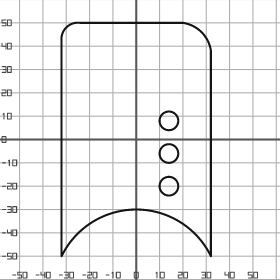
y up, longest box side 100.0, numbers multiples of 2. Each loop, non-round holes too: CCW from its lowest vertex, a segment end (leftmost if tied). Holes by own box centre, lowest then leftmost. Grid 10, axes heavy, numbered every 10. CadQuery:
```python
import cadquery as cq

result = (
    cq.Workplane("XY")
    .moveTo(-32.0, -50.0)
    .threePointArc((0.0, -30.0), (32.0, -50.0))
    .lineTo(32.0, 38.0)
    .threePointArc((28.0, 46.0), (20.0, 50.0))
    .lineTo(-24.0, 50.0)
    .threePointArc((-30.0, 48.0), (-32.0, 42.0))
    .close()
    .moveTo(14.0, -20.0)
    .circle(4.0)
    .moveTo(14.0, -6.0)
    .circle(4.0)
    .moveTo(14.0, 8.0)
    .circle(4.0)
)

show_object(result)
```